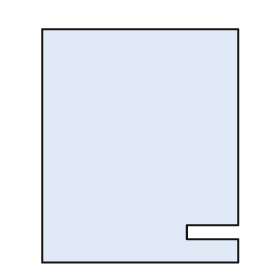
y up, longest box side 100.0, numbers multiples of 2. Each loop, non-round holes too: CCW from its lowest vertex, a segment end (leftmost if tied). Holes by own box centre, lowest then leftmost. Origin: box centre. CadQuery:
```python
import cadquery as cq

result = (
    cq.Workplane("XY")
    .moveTo(-42.0, -50.0)
    .lineTo(42.0, -50.0)
    .lineTo(42.0, -40.0)
    .lineTo(20.0, -40.0)
    .lineTo(20.0, -34.0)
    .lineTo(42.0, -34.0)
    .lineTo(42.0, 50.0)
    .lineTo(-42.0, 50.0)
    .close()
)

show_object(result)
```